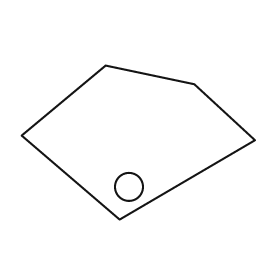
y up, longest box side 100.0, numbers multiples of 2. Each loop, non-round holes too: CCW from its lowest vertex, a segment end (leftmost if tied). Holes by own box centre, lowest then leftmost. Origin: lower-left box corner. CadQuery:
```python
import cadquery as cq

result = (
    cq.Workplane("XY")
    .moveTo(42.0, 0.0)
    .lineTo(100.0, 34.0)
    .lineTo(74.0, 58.0)
    .lineTo(36.0, 66.0)
    .lineTo(0.0, 36.0)
    .close()
    .moveTo(46.0, 14.0)
    .circle(6.0)
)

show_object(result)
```